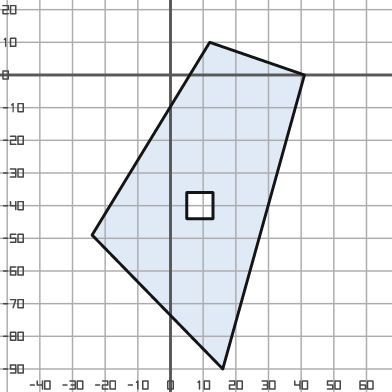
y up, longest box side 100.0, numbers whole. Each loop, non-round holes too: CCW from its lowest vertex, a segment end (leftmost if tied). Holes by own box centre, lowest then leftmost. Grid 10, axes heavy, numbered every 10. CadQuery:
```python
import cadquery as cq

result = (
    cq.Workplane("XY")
    .moveTo(16.0, -90.0)
    .lineTo(41.0, 0.0)
    .lineTo(12.0, 10.0)
    .lineTo(-24.0, -49.0)
    .close()
    .moveTo(5.0, -44.0)
    .lineTo(13.0, -44.0)
    .lineTo(13.0, -36.0)
    .lineTo(5.0, -36.0)
    .close()
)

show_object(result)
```